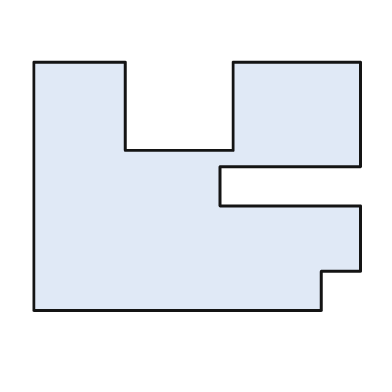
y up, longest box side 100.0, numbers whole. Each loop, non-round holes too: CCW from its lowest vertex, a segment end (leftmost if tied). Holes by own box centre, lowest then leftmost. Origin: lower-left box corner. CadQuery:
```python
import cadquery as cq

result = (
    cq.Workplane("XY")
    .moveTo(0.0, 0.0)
    .lineTo(88.0, 0.0)
    .lineTo(88.0, 12.0)
    .lineTo(100.0, 12.0)
    .lineTo(100.0, 32.0)
    .lineTo(57.0, 32.0)
    .lineTo(57.0, 44.0)
    .lineTo(100.0, 44.0)
    .lineTo(100.0, 76.0)
    .lineTo(61.0, 76.0)
    .lineTo(61.0, 49.0)
    .lineTo(28.0, 49.0)
    .lineTo(28.0, 76.0)
    .lineTo(0.0, 76.0)
    .close()
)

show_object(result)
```